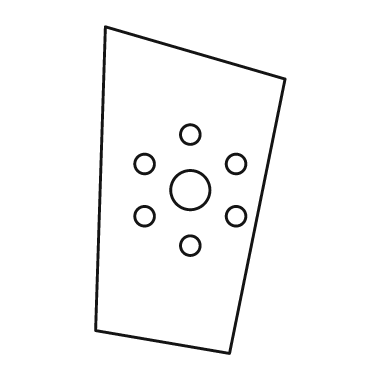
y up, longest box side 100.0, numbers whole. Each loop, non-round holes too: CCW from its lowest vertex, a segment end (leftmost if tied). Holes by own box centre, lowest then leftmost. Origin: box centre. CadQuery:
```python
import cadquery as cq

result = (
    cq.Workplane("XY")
    .moveTo(12.0, -50.0)
    .lineTo(29.0, 34.0)
    .lineTo(-26.0, 50.0)
    .lineTo(-29.0, -43.0)
    .close()
    .moveTo(0.0, -17.0)
    .circle(3.0)
    .moveTo(-14.0, -8.0)
    .circle(3.0)
    .moveTo(14.0, -8.0)
    .circle(3.0)
    .moveTo(0.0, 0.0)
    .circle(6.0)
    .moveTo(-14.0, 8.0)
    .circle(3.0)
    .moveTo(14.0, 8.0)
    .circle(3.0)
    .moveTo(0.0, 17.0)
    .circle(3.0)
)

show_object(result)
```